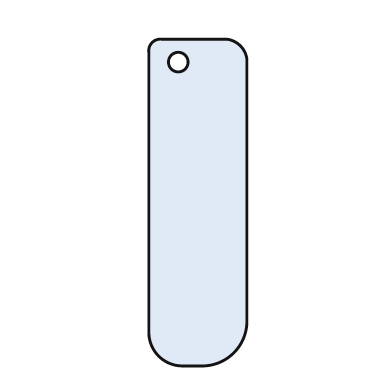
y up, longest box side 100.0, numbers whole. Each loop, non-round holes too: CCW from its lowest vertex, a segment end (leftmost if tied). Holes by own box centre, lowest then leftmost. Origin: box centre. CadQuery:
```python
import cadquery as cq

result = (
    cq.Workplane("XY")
    .moveTo(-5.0, -50.0)
    .lineTo(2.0, -50.0)
    .threePointArc((11.0, -46.0), (15.0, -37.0))
    .lineTo(15.0, 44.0)
    .threePointArc((13.0, 48.0), (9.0, 50.0))
    .lineTo(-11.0, 50.0)
    .threePointArc((-14.0, 49.0), (-15.0, 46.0))
    .lineTo(-15.0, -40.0)
    .threePointArc((-12.0, -47.0), (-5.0, -50.0))
    .close()
    .moveTo(-6.0, 43.0)
    .circle(3.0)
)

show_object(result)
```